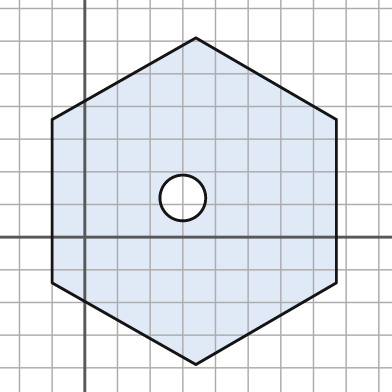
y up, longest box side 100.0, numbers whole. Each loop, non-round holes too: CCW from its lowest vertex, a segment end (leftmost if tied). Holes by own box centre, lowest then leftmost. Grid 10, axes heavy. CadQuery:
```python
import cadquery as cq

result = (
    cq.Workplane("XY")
    .moveTo(34.0, -39.0)
    .lineTo(77.0, -14.0)
    .lineTo(77.0, 36.0)
    .lineTo(34.0, 61.0)
    .lineTo(-10.0, 36.0)
    .lineTo(-10.0, -14.0)
    .close()
    .moveTo(30.0, 12.0)
    .circle(7.0)
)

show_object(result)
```